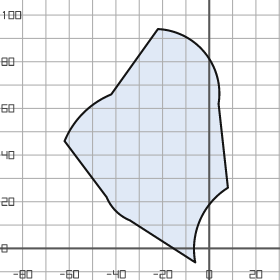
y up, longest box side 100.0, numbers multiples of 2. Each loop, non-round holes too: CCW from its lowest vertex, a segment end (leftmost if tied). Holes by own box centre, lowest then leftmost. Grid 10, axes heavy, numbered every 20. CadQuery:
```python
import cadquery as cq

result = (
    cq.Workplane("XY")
    .moveTo(-6.0, -6.0)
    .threePointArc((-4.0, 12.0), (8.0, 26.0))
    .lineTo(4.0, 62.0)
    .threePointArc((-2.0, 84.0), (-22.0, 94.0))
    .lineTo(-42.0, 66.0)
    .threePointArc((-54.0, 58.0), (-62.0, 46.0))
    .lineTo(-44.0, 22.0)
    .threePointArc((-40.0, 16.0), (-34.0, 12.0))
    .close()
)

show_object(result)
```